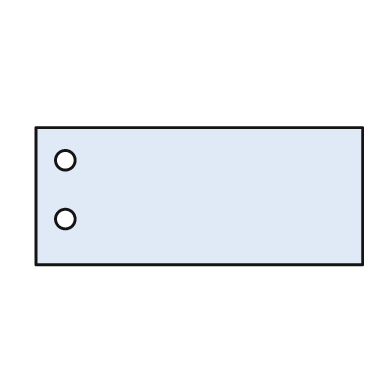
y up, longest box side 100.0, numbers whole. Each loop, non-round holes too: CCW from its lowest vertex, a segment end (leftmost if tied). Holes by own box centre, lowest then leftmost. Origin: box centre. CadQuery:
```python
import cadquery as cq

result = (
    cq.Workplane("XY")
    .moveTo(-50.0, -21.0)
    .lineTo(50.0, -21.0)
    .lineTo(50.0, 21.0)
    .lineTo(-50.0, 21.0)
    .close()
    .moveTo(-41.0, -7.0)
    .circle(3.0)
    .moveTo(-41.0, 11.0)
    .circle(3.0)
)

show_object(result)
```